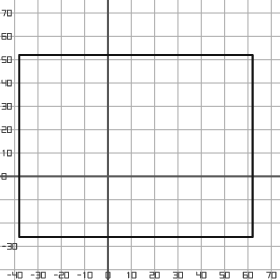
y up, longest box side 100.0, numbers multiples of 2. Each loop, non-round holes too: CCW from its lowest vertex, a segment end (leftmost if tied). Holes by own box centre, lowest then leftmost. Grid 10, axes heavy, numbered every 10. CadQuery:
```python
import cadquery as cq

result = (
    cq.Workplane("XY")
    .moveTo(-38.0, -26.0)
    .lineTo(62.0, -26.0)
    .lineTo(62.0, 52.0)
    .lineTo(-38.0, 52.0)
    .close()
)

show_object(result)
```